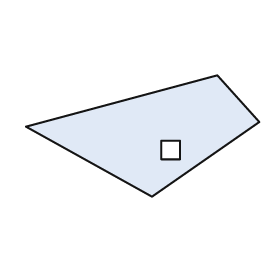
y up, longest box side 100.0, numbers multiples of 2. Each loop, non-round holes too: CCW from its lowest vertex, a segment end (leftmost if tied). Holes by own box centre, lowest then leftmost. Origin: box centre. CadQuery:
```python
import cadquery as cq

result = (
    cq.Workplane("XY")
    .moveTo(4.0, -26.0)
    .lineTo(50.0, 6.0)
    .lineTo(32.0, 26.0)
    .lineTo(-50.0, 4.0)
    .close()
    .moveTo(8.0, -10.0)
    .lineTo(16.0, -10.0)
    .lineTo(16.0, -2.0)
    .lineTo(8.0, -2.0)
    .close()
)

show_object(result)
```